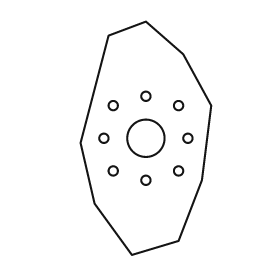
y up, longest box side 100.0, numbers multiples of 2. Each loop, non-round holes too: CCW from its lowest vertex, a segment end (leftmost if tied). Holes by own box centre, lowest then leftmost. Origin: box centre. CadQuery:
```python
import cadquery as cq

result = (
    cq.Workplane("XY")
    .moveTo(-6.0, -50.0)
    .lineTo(14.0, -44.0)
    .lineTo(24.0, -18.0)
    .lineTo(28.0, 14.0)
    .lineTo(16.0, 36.0)
    .lineTo(0.0, 50.0)
    .lineTo(-16.0, 44.0)
    .lineTo(-28.0, -2.0)
    .lineTo(-22.0, -28.0)
    .close()
    .moveTo(0.0, -18.0)
    .circle(2.0)
    .moveTo(-14.0, -14.0)
    .circle(2.0)
    .moveTo(14.0, -14.0)
    .circle(2.0)
    .moveTo(-18.0, 0.0)
    .circle(2.0)
    .moveTo(0.0, 0.0)
    .circle(8.0)
    .moveTo(18.0, 0.0)
    .circle(2.0)
    .moveTo(-14.0, 14.0)
    .circle(2.0)
    .moveTo(14.0, 14.0)
    .circle(2.0)
    .moveTo(0.0, 18.0)
    .circle(2.0)
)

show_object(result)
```